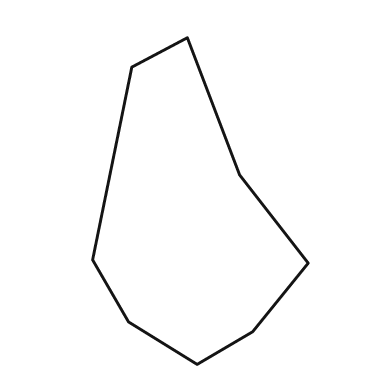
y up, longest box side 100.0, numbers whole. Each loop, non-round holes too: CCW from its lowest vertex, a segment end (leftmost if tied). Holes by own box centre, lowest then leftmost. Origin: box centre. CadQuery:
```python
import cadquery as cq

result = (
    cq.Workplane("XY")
    .moveTo(-1.0, -50.0)
    .lineTo(16.0, -40.0)
    .lineTo(33.0, -19.0)
    .lineTo(12.0, 8.0)
    .lineTo(-4.0, 50.0)
    .lineTo(-21.0, 41.0)
    .lineTo(-33.0, -18.0)
    .lineTo(-22.0, -37.0)
    .close()
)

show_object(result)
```